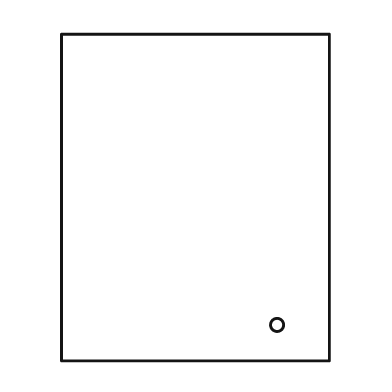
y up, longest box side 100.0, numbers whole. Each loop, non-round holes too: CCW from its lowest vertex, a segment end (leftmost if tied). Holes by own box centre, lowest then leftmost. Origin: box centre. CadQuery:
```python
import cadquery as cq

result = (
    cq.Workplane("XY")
    .moveTo(-41.0, -50.0)
    .lineTo(41.0, -50.0)
    .lineTo(41.0, 50.0)
    .lineTo(-41.0, 50.0)
    .close()
    .moveTo(25.0, -39.0)
    .circle(2.0)
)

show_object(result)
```